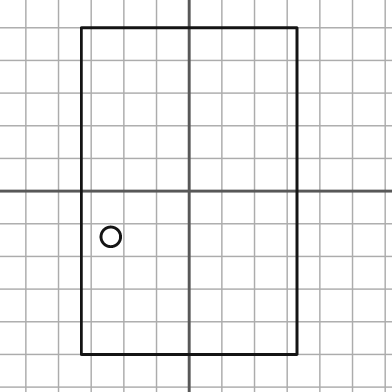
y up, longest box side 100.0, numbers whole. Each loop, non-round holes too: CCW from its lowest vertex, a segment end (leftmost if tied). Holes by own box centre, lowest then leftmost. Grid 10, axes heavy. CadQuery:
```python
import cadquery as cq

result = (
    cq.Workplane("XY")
    .moveTo(-33.0, -50.0)
    .lineTo(33.0, -50.0)
    .lineTo(33.0, 50.0)
    .lineTo(-33.0, 50.0)
    .close()
    .moveTo(-24.0, -14.0)
    .circle(3.0)
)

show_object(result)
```